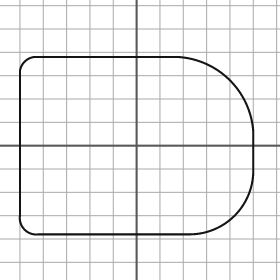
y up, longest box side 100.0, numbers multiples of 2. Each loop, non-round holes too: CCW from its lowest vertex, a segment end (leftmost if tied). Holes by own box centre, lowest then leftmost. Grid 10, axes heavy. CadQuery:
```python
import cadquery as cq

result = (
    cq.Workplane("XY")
    .moveTo(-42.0, -38.0)
    .lineTo(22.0, -38.0)
    .threePointArc((42.0, -30.0), (50.0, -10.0))
    .lineTo(50.0, 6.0)
    .threePointArc((40.0, 28.0), (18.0, 38.0))
    .lineTo(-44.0, 38.0)
    .threePointArc((-48.0, 36.0), (-50.0, 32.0))
    .lineTo(-50.0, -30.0)
    .threePointArc((-48.0, -36.0), (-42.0, -38.0))
    .close()
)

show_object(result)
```